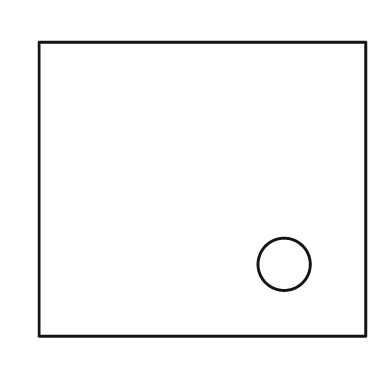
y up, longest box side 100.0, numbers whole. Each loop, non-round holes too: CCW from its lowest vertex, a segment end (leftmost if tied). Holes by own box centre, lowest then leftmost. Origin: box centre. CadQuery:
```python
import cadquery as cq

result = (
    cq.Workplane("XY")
    .moveTo(-50.0, -45.0)
    .lineTo(50.0, -45.0)
    .lineTo(50.0, 45.0)
    .lineTo(-50.0, 45.0)
    .close()
    .moveTo(25.0, -23.0)
    .circle(8.0)
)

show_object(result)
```